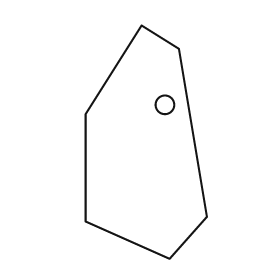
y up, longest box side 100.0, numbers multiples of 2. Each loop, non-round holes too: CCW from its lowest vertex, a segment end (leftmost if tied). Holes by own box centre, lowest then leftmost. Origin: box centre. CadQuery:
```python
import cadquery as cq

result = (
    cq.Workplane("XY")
    .moveTo(10.0, -50.0)
    .lineTo(26.0, -32.0)
    .lineTo(14.0, 40.0)
    .lineTo(-2.0, 50.0)
    .lineTo(-26.0, 12.0)
    .lineTo(-26.0, -34.0)
    .close()
    .moveTo(8.0, 16.0)
    .circle(4.0)
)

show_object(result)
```